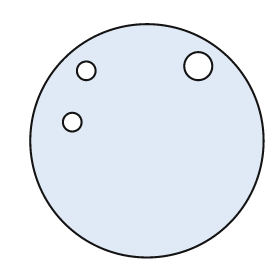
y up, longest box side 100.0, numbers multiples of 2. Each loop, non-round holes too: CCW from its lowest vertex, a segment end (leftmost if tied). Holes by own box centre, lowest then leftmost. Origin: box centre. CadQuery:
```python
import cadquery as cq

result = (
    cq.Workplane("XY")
    .moveTo(0.0, 0.0)
    .circle(50.0)
    .moveTo(-32.0, 8.0)
    .circle(4.0)
    .moveTo(-26.0, 30.0)
    .circle(4.0)
    .moveTo(22.0, 32.0)
    .circle(6.0)
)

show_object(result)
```